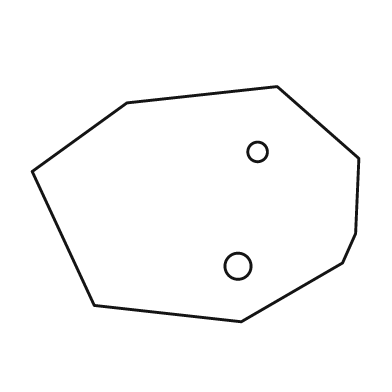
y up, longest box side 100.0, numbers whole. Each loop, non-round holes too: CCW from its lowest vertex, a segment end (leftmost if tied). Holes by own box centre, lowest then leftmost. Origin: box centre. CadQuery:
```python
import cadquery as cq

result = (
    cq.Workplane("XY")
    .moveTo(14.0, -36.0)
    .lineTo(45.0, -18.0)
    .lineTo(49.0, -9.0)
    .lineTo(50.0, 14.0)
    .lineTo(25.0, 36.0)
    .lineTo(-21.0, 31.0)
    .lineTo(-50.0, 10.0)
    .lineTo(-31.0, -31.0)
    .close()
    .moveTo(13.0, -19.0)
    .circle(4.0)
    .moveTo(19.0, 16.0)
    .circle(3.0)
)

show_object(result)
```